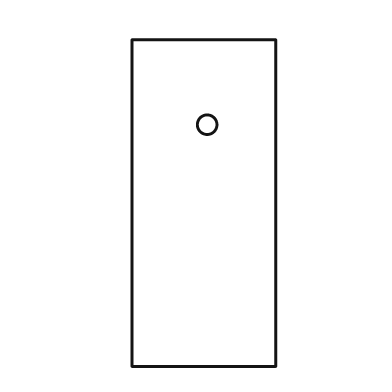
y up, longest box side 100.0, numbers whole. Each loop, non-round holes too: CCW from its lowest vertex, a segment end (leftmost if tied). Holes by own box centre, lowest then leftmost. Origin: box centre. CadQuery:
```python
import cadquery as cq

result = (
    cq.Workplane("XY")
    .moveTo(-22.0, -50.0)
    .lineTo(22.0, -50.0)
    .lineTo(22.0, 50.0)
    .lineTo(-22.0, 50.0)
    .close()
    .moveTo(1.0, 24.0)
    .circle(3.0)
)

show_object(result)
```